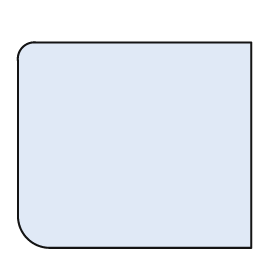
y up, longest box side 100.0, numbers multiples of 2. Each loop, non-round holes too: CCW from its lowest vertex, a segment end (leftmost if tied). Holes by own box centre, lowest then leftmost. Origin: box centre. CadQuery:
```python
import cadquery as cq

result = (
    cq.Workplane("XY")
    .moveTo(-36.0, -44.0)
    .lineTo(50.0, -44.0)
    .lineTo(50.0, 44.0)
    .lineTo(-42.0, 44.0)
    .threePointArc((-48.0, 42.0), (-50.0, 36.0))
    .lineTo(-50.0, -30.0)
    .threePointArc((-46.0, -40.0), (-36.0, -44.0))
    .close()
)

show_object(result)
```